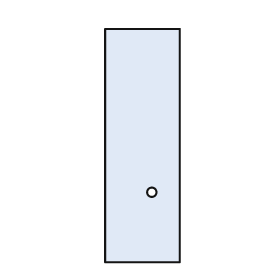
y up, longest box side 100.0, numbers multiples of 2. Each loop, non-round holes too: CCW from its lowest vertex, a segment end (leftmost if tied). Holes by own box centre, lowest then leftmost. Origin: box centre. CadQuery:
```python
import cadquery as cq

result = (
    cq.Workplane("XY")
    .moveTo(-16.0, -50.0)
    .lineTo(16.0, -50.0)
    .lineTo(16.0, 50.0)
    .lineTo(-16.0, 50.0)
    .close()
    .moveTo(4.0, -20.0)
    .circle(2.0)
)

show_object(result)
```